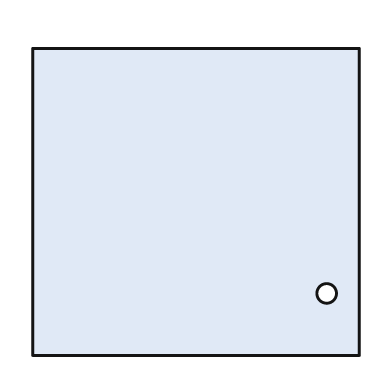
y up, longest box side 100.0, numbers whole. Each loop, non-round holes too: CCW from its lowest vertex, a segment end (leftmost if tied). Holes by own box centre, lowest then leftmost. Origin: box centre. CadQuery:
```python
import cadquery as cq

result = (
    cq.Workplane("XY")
    .moveTo(-50.0, -47.0)
    .lineTo(50.0, -47.0)
    .lineTo(50.0, 47.0)
    .lineTo(-50.0, 47.0)
    .close()
    .moveTo(40.0, -28.0)
    .circle(3.0)
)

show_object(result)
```